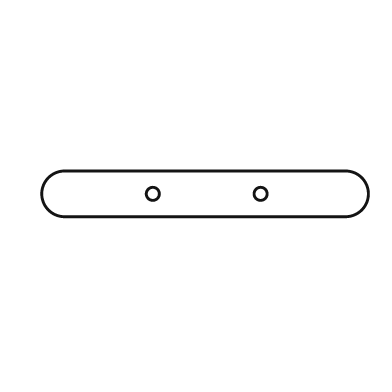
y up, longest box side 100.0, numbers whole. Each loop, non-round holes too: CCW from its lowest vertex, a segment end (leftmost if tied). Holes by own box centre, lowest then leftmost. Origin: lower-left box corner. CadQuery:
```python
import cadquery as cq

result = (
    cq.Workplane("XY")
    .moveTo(7.0, 0.0)
    .lineTo(93.0, 0.0)
    .threePointArc((100.0, 7.0), (93.0, 14.0))
    .lineTo(7.0, 14.0)
    .threePointArc((0.0, 7.0), (7.0, 0.0))
    .close()
    .moveTo(34.0, 7.0)
    .circle(2.0)
    .moveTo(67.0, 7.0)
    .circle(2.0)
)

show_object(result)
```